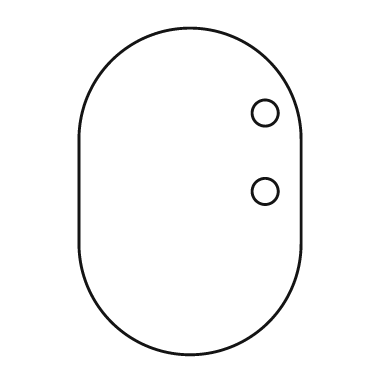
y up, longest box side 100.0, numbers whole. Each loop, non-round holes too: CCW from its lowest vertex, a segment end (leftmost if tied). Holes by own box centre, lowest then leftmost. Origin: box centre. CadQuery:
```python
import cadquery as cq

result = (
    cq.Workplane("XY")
    .moveTo(-34.0, -16.0)
    .threePointArc((0.0, -50.0), (34.0, -16.0))
    .lineTo(34.0, 16.0)
    .threePointArc((0.0, 50.0), (-34.0, 16.0))
    .close()
    .moveTo(23.0, 0.0)
    .circle(4.0)
    .moveTo(23.0, 24.0)
    .circle(4.0)
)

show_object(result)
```